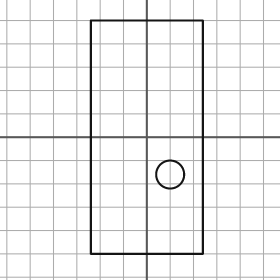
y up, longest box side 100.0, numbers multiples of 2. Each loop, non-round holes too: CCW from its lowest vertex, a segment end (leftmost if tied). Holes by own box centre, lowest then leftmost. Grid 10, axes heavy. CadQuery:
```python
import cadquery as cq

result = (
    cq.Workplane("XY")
    .moveTo(-24.0, -50.0)
    .lineTo(24.0, -50.0)
    .lineTo(24.0, 50.0)
    .lineTo(-24.0, 50.0)
    .close()
    .moveTo(10.0, -16.0)
    .circle(6.0)
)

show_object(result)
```